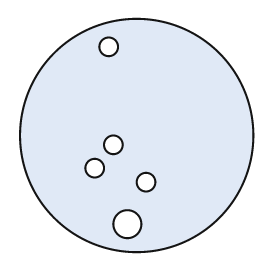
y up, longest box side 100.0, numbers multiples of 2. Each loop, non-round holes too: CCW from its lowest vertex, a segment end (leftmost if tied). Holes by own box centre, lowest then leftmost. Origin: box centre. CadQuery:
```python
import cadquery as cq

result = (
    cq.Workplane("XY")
    .moveTo(0.0, 0.0)
    .circle(50.0)
    .moveTo(-4.0, -38.0)
    .circle(6.0)
    .moveTo(4.0, -20.0)
    .circle(4.0)
    .moveTo(-18.0, -14.0)
    .circle(4.0)
    .moveTo(-10.0, -4.0)
    .circle(4.0)
    .moveTo(-12.0, 38.0)
    .circle(4.0)
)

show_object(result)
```